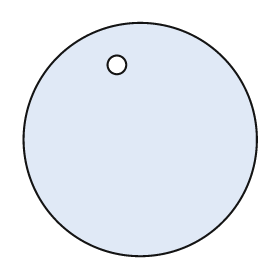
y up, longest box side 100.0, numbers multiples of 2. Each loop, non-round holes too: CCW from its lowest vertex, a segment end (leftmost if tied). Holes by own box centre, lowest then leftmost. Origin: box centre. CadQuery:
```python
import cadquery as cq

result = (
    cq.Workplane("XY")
    .moveTo(0.0, 0.0)
    .circle(50.0)
    .moveTo(-10.0, 32.0)
    .circle(4.0)
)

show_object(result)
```